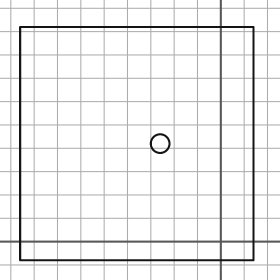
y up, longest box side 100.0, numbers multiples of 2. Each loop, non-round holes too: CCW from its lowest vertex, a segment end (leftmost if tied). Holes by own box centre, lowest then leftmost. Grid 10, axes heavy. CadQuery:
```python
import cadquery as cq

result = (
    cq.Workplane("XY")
    .moveTo(-86.0, -8.0)
    .lineTo(14.0, -8.0)
    .lineTo(14.0, 92.0)
    .lineTo(-86.0, 92.0)
    .close()
    .moveTo(-26.0, 42.0)
    .circle(4.0)
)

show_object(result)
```